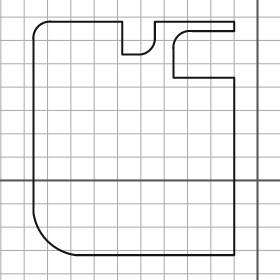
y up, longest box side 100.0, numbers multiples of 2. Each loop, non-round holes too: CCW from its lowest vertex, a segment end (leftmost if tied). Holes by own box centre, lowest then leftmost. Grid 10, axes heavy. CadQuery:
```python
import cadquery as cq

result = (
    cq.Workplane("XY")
    .moveTo(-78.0, -32.0)
    .lineTo(-10.0, -32.0)
    .lineTo(-10.0, 44.0)
    .lineTo(-36.0, 44.0)
    .lineTo(-36.0, 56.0)
    .threePointArc((-34.0, 62.0), (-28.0, 64.0))
    .lineTo(-10.0, 64.0)
    .lineTo(-10.0, 68.0)
    .lineTo(-44.0, 68.0)
    .lineTo(-44.0, 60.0)
    .threePointArc((-46.0, 56.0), (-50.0, 54.0))
    .lineTo(-58.0, 54.0)
    .lineTo(-58.0, 68.0)
    .lineTo(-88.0, 68.0)
    .threePointArc((-94.0, 66.0), (-96.0, 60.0))
    .lineTo(-96.0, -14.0)
    .threePointArc((-90.0, -26.0), (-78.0, -32.0))
    .close()
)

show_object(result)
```